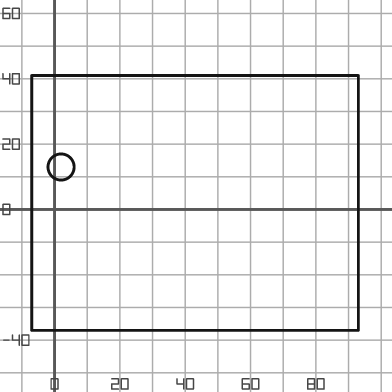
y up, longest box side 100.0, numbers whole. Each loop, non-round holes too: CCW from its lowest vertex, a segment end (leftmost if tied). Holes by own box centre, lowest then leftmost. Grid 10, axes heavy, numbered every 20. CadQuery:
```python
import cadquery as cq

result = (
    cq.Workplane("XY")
    .moveTo(-7.0, -37.0)
    .lineTo(93.0, -37.0)
    .lineTo(93.0, 41.0)
    .lineTo(-7.0, 41.0)
    .close()
    .moveTo(2.0, 13.0)
    .circle(4.0)
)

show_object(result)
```